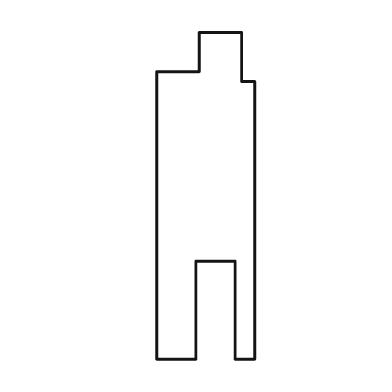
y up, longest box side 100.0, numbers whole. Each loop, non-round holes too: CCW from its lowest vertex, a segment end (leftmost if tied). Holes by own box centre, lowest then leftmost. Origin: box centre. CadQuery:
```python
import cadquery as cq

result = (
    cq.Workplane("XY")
    .moveTo(-15.0, -50.0)
    .lineTo(-3.0, -50.0)
    .lineTo(-3.0, -20.0)
    .lineTo(9.0, -20.0)
    .lineTo(9.0, -50.0)
    .lineTo(15.0, -50.0)
    .lineTo(15.0, 35.0)
    .lineTo(11.0, 35.0)
    .lineTo(11.0, 50.0)
    .lineTo(-2.0, 50.0)
    .lineTo(-2.0, 38.0)
    .lineTo(-15.0, 38.0)
    .close()
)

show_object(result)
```